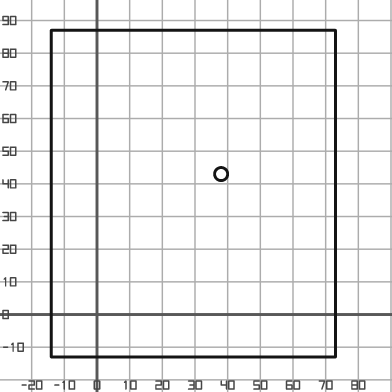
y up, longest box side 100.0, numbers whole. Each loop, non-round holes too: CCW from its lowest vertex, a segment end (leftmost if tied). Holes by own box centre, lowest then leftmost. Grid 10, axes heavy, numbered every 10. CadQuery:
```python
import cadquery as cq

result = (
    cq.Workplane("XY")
    .moveTo(-14.0, -13.0)
    .lineTo(73.0, -13.0)
    .lineTo(73.0, 87.0)
    .lineTo(-14.0, 87.0)
    .close()
    .moveTo(38.0, 43.0)
    .circle(2.0)
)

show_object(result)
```